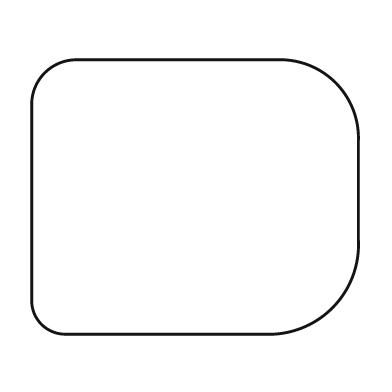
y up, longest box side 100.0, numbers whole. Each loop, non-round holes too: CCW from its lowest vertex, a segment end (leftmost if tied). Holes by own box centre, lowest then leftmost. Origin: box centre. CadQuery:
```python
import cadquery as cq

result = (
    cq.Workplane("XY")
    .moveTo(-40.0, -42.0)
    .lineTo(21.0, -42.0)
    .threePointArc((42.0, -34.0), (50.0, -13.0))
    .lineTo(50.0, 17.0)
    .threePointArc((43.0, 35.0), (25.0, 42.0))
    .lineTo(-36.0, 42.0)
    .threePointArc((-46.0, 38.0), (-50.0, 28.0))
    .lineTo(-50.0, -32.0)
    .threePointArc((-47.0, -39.0), (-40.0, -42.0))
    .close()
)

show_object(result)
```